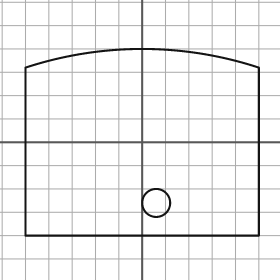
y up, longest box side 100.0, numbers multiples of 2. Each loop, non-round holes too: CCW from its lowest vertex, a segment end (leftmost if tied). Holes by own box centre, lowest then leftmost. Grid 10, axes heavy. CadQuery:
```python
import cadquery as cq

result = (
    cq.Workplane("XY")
    .moveTo(-50.0, -40.0)
    .lineTo(50.0, -40.0)
    .lineTo(50.0, 32.0)
    .threePointArc((0.0, 40.0), (-50.0, 32.0))
    .close()
    .moveTo(6.0, -26.0)
    .circle(6.0)
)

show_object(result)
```